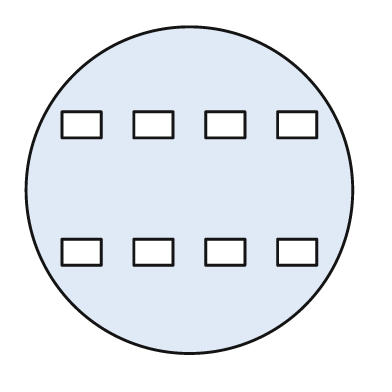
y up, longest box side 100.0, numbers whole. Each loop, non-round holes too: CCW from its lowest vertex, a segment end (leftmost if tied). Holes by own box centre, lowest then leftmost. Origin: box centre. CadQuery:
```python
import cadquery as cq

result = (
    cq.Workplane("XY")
    .moveTo(0.0, 0.0)
    .circle(50.0)
    .moveTo(-39.0, -23.0)
    .lineTo(-27.0, -23.0)
    .lineTo(-27.0, -15.0)
    .lineTo(-39.0, -15.0)
    .close()
    .moveTo(-17.0, -23.0)
    .lineTo(-5.0, -23.0)
    .lineTo(-5.0, -15.0)
    .lineTo(-17.0, -15.0)
    .close()
    .moveTo(5.0, -23.0)
    .lineTo(17.0, -23.0)
    .lineTo(17.0, -15.0)
    .lineTo(5.0, -15.0)
    .close()
    .moveTo(27.0, -23.0)
    .lineTo(39.0, -23.0)
    .lineTo(39.0, -15.0)
    .lineTo(27.0, -15.0)
    .close()
    .moveTo(-39.0, 16.0)
    .lineTo(-27.0, 16.0)
    .lineTo(-27.0, 24.0)
    .lineTo(-39.0, 24.0)
    .close()
    .moveTo(-17.0, 16.0)
    .lineTo(-5.0, 16.0)
    .lineTo(-5.0, 24.0)
    .lineTo(-17.0, 24.0)
    .close()
    .moveTo(5.0, 16.0)
    .lineTo(17.0, 16.0)
    .lineTo(17.0, 24.0)
    .lineTo(5.0, 24.0)
    .close()
    .moveTo(27.0, 16.0)
    .lineTo(39.0, 16.0)
    .lineTo(39.0, 24.0)
    .lineTo(27.0, 24.0)
    .close()
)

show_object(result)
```